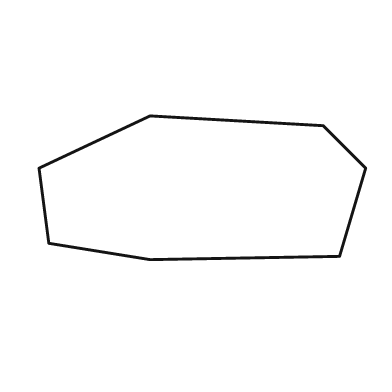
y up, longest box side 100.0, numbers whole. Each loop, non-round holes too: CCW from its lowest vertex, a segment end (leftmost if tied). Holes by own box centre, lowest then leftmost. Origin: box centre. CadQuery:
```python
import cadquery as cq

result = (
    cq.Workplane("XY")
    .moveTo(-16.0, -22.0)
    .lineTo(42.0, -21.0)
    .lineTo(50.0, 6.0)
    .lineTo(37.0, 19.0)
    .lineTo(-16.0, 22.0)
    .lineTo(-50.0, 6.0)
    .lineTo(-47.0, -17.0)
    .close()
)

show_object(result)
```